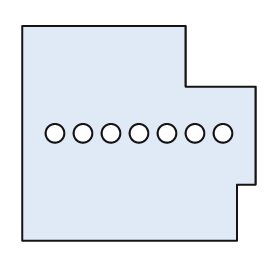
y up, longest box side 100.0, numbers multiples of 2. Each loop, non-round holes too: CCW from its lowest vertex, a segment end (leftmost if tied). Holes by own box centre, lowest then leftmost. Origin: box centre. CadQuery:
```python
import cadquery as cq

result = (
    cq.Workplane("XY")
    .moveTo(-50.0, -46.0)
    .lineTo(42.0, -46.0)
    .lineTo(42.0, -22.0)
    .lineTo(50.0, -22.0)
    .lineTo(50.0, 20.0)
    .lineTo(20.0, 20.0)
    .lineTo(20.0, 46.0)
    .lineTo(-50.0, 46.0)
    .close()
    .moveTo(-36.0, 0.0)
    .circle(4.0)
    .moveTo(-24.0, 0.0)
    .circle(4.0)
    .moveTo(-12.0, 0.0)
    .circle(4.0)
    .moveTo(0.0, 0.0)
    .circle(4.0)
    .moveTo(12.0, 0.0)
    .circle(4.0)
    .moveTo(24.0, 0.0)
    .circle(4.0)
    .moveTo(36.0, 0.0)
    .circle(4.0)
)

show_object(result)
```